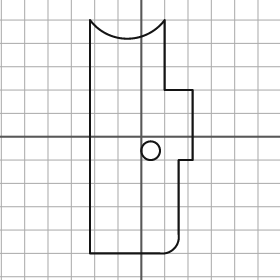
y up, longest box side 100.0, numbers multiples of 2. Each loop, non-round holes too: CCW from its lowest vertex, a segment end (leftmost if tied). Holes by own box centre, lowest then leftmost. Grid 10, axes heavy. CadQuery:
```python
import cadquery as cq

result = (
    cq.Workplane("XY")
    .moveTo(-22.0, -50.0)
    .lineTo(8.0, -50.0)
    .threePointArc((14.0, -48.0), (16.0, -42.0))
    .lineTo(16.0, -10.0)
    .lineTo(22.0, -10.0)
    .lineTo(22.0, 20.0)
    .lineTo(10.0, 20.0)
    .lineTo(10.0, 50.0)
    .threePointArc((-6.0, 42.0), (-22.0, 50.0))
    .close()
    .moveTo(4.0, -6.0)
    .circle(4.0)
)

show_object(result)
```